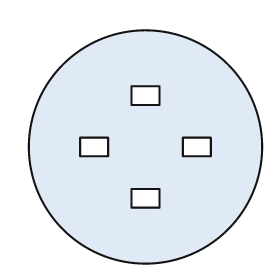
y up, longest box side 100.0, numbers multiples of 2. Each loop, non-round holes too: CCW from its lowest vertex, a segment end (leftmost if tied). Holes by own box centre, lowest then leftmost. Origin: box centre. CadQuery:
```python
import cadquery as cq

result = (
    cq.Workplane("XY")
    .moveTo(0.0, 0.0)
    .circle(50.0)
    .moveTo(-6.0, -26.0)
    .lineTo(6.0, -26.0)
    .lineTo(6.0, -18.0)
    .lineTo(-6.0, -18.0)
    .close()
    .moveTo(-28.0, -4.0)
    .lineTo(-16.0, -4.0)
    .lineTo(-16.0, 4.0)
    .lineTo(-28.0, 4.0)
    .close()
    .moveTo(16.0, -4.0)
    .lineTo(28.0, -4.0)
    .lineTo(28.0, 4.0)
    .lineTo(16.0, 4.0)
    .close()
    .moveTo(-6.0, 18.0)
    .lineTo(6.0, 18.0)
    .lineTo(6.0, 26.0)
    .lineTo(-6.0, 26.0)
    .close()
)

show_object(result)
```